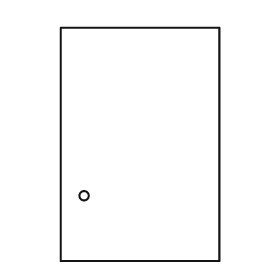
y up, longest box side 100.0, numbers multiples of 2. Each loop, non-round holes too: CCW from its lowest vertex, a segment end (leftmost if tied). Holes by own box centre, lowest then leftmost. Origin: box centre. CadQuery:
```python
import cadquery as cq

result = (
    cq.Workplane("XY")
    .moveTo(-34.0, -50.0)
    .lineTo(34.0, -50.0)
    .lineTo(34.0, 50.0)
    .lineTo(-34.0, 50.0)
    .close()
    .moveTo(-24.0, -22.0)
    .circle(2.0)
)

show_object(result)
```